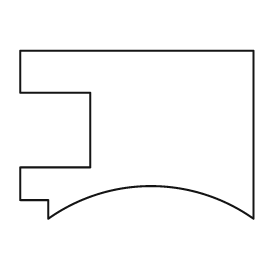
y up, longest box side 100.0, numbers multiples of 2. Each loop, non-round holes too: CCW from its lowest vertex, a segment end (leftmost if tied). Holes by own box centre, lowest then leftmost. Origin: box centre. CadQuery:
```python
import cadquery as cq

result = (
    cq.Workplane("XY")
    .moveTo(-38.0, -36.0)
    .threePointArc((6.0, -22.0), (50.0, -36.0))
    .lineTo(50.0, 36.0)
    .lineTo(-50.0, 36.0)
    .lineTo(-50.0, 18.0)
    .lineTo(-20.0, 18.0)
    .lineTo(-20.0, -14.0)
    .lineTo(-50.0, -14.0)
    .lineTo(-50.0, -28.0)
    .lineTo(-38.0, -28.0)
    .close()
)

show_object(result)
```